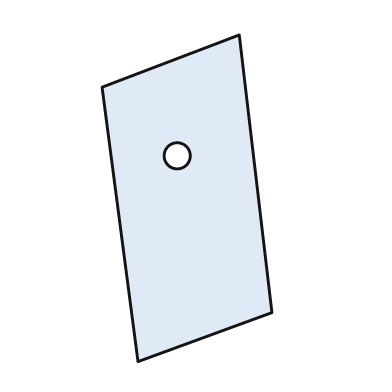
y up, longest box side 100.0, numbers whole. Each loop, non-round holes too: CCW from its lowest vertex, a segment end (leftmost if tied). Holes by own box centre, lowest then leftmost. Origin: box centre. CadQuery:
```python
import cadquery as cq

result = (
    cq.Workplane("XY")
    .moveTo(-15.0, -50.0)
    .lineTo(26.0, -35.0)
    .lineTo(16.0, 50.0)
    .lineTo(-26.0, 34.0)
    .close()
    .moveTo(-3.0, 13.0)
    .circle(4.0)
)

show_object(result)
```